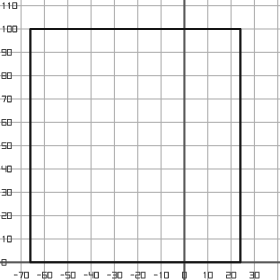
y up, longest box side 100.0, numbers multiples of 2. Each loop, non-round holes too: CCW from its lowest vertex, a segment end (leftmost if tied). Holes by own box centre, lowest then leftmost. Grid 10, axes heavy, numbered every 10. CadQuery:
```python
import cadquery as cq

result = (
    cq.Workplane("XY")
    .moveTo(-66.0, 0.0)
    .lineTo(24.0, 0.0)
    .lineTo(24.0, 100.0)
    .lineTo(-66.0, 100.0)
    .close()
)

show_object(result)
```